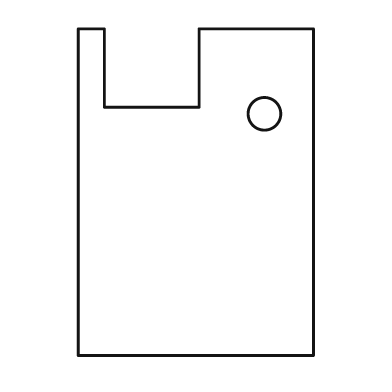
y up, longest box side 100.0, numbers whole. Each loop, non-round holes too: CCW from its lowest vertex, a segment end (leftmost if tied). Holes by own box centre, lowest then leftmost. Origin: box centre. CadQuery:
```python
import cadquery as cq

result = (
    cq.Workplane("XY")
    .moveTo(-36.0, -50.0)
    .lineTo(36.0, -50.0)
    .lineTo(36.0, 50.0)
    .lineTo(1.0, 50.0)
    .lineTo(1.0, 26.0)
    .lineTo(-28.0, 26.0)
    .lineTo(-28.0, 50.0)
    .lineTo(-36.0, 50.0)
    .close()
    .moveTo(21.0, 24.0)
    .circle(5.0)
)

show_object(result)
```